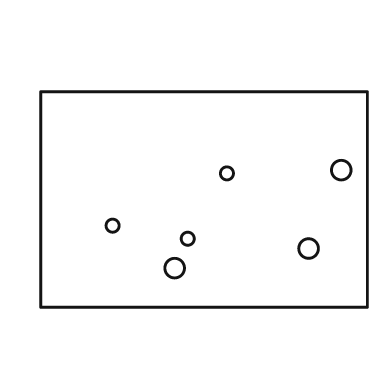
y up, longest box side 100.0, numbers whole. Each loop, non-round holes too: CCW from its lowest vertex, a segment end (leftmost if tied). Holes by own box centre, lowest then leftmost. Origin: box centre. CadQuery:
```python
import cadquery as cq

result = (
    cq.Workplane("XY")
    .moveTo(-50.0, -33.0)
    .lineTo(50.0, -33.0)
    .lineTo(50.0, 33.0)
    .lineTo(-50.0, 33.0)
    .close()
    .moveTo(-9.0, -21.0)
    .circle(3.0)
    .moveTo(32.0, -15.0)
    .circle(3.0)
    .moveTo(-5.0, -12.0)
    .circle(2.0)
    .moveTo(-28.0, -8.0)
    .circle(2.0)
    .moveTo(7.0, 8.0)
    .circle(2.0)
    .moveTo(42.0, 9.0)
    .circle(3.0)
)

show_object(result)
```